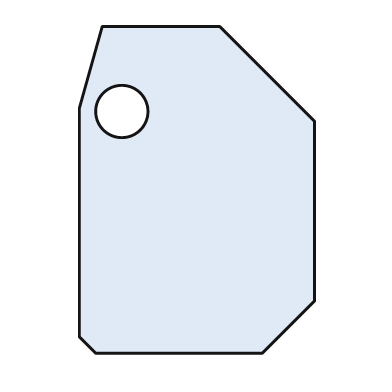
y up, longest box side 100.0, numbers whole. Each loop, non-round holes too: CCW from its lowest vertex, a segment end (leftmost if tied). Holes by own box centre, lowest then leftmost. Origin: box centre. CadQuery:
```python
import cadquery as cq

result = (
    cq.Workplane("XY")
    .moveTo(-31.0, -50.0)
    .lineTo(20.0, -50.0)
    .lineTo(36.0, -34.0)
    .lineTo(36.0, 21.0)
    .lineTo(7.0, 50.0)
    .lineTo(-29.0, 50.0)
    .lineTo(-36.0, 25.0)
    .lineTo(-36.0, -45.0)
    .close()
    .moveTo(-23.0, 24.0)
    .circle(8.0)
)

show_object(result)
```